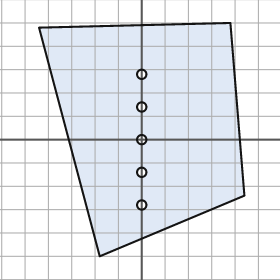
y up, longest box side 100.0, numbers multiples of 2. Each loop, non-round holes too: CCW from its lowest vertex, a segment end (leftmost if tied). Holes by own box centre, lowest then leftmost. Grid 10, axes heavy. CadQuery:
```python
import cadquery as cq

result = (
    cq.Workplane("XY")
    .moveTo(-18.0, -50.0)
    .lineTo(44.0, -24.0)
    .lineTo(38.0, 50.0)
    .lineTo(-44.0, 48.0)
    .close()
    .moveTo(0.0, -28.0)
    .circle(2.0)
    .moveTo(0.0, -14.0)
    .circle(2.0)
    .moveTo(0.0, 0.0)
    .circle(2.0)
    .moveTo(0.0, 14.0)
    .circle(2.0)
    .moveTo(0.0, 28.0)
    .circle(2.0)
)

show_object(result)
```